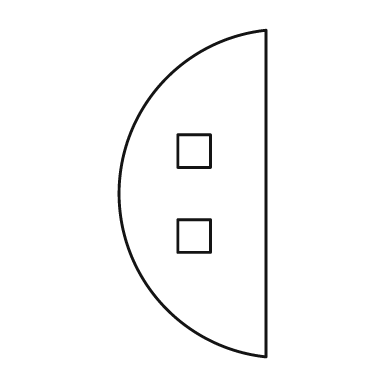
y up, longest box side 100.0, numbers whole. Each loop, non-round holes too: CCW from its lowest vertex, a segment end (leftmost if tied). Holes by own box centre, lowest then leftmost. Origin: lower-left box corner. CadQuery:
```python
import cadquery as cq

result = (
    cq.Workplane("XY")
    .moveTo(45.0, 0.0)
    .lineTo(45.0, 100.0)
    .threePointArc((0.0, 50.0), (45.0, 0.0))
    .close()
    .moveTo(18.0, 32.0)
    .lineTo(28.0, 32.0)
    .lineTo(28.0, 42.0)
    .lineTo(18.0, 42.0)
    .close()
    .moveTo(18.0, 58.0)
    .lineTo(28.0, 58.0)
    .lineTo(28.0, 68.0)
    .lineTo(18.0, 68.0)
    .close()
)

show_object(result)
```